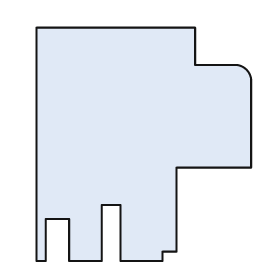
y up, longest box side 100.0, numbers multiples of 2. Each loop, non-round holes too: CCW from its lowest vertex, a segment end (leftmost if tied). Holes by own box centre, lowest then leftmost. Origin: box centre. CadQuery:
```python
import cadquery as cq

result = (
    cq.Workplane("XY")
    .moveTo(-46.0, -50.0)
    .lineTo(-42.0, -50.0)
    .lineTo(-42.0, -32.0)
    .lineTo(-32.0, -32.0)
    .lineTo(-32.0, -50.0)
    .lineTo(-18.0, -50.0)
    .lineTo(-18.0, -26.0)
    .lineTo(-10.0, -26.0)
    .lineTo(-10.0, -50.0)
    .lineTo(8.0, -50.0)
    .lineTo(8.0, -46.0)
    .lineTo(14.0, -46.0)
    .lineTo(14.0, -10.0)
    .lineTo(46.0, -10.0)
    .lineTo(46.0, 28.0)
    .threePointArc((44.0, 32.0), (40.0, 34.0))
    .lineTo(22.0, 34.0)
    .lineTo(22.0, 50.0)
    .lineTo(-46.0, 50.0)
    .close()
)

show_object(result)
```